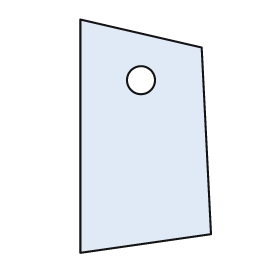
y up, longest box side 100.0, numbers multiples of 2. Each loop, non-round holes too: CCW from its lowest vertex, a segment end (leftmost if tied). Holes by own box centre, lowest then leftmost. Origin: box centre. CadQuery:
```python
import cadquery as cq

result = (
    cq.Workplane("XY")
    .moveTo(-28.0, -50.0)
    .lineTo(28.0, -42.0)
    .lineTo(24.0, 38.0)
    .lineTo(-28.0, 50.0)
    .close()
    .moveTo(-2.0, 24.0)
    .circle(6.0)
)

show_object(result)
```